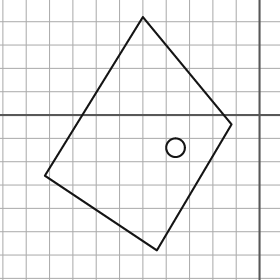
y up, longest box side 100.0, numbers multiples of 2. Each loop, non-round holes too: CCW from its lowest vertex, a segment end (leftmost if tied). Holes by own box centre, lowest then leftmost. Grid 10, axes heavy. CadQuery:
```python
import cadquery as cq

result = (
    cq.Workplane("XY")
    .moveTo(-44.0, -58.0)
    .lineTo(-12.0, -4.0)
    .lineTo(-50.0, 42.0)
    .lineTo(-92.0, -26.0)
    .close()
    .moveTo(-36.0, -14.0)
    .circle(4.0)
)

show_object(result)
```